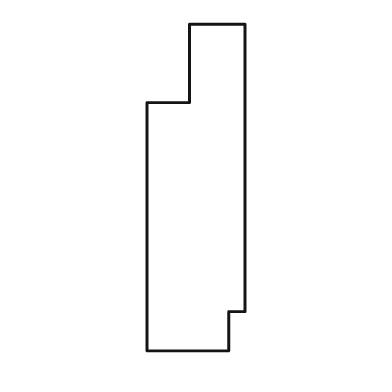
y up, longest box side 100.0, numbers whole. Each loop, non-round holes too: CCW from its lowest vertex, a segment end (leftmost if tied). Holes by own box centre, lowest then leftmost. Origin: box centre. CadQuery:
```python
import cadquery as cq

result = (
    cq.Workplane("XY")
    .moveTo(-15.0, -50.0)
    .lineTo(10.0, -50.0)
    .lineTo(10.0, -38.0)
    .lineTo(15.0, -38.0)
    .lineTo(15.0, 50.0)
    .lineTo(-2.0, 50.0)
    .lineTo(-2.0, 26.0)
    .lineTo(-15.0, 26.0)
    .close()
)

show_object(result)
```